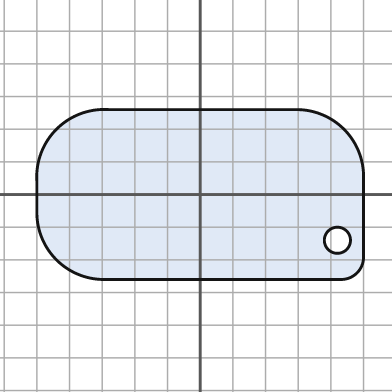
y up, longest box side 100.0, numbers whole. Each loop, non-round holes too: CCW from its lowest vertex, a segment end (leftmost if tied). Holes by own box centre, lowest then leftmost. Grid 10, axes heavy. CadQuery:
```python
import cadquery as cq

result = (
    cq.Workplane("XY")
    .moveTo(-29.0, -26.0)
    .lineTo(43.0, -26.0)
    .threePointArc((48.0, -24.0), (50.0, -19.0))
    .lineTo(50.0, 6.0)
    .threePointArc((44.0, 20.0), (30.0, 26.0))
    .lineTo(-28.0, 26.0)
    .threePointArc((-44.0, 20.0), (-50.0, 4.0))
    .lineTo(-50.0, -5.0)
    .threePointArc((-44.0, -20.0), (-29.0, -26.0))
    .close()
    .moveTo(42.0, -14.0)
    .circle(4.0)
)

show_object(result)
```